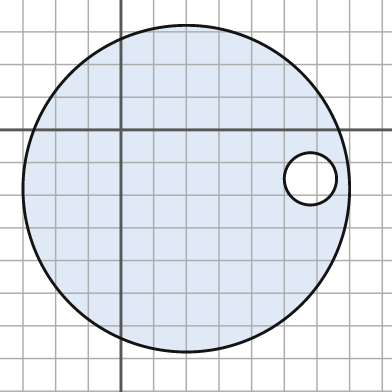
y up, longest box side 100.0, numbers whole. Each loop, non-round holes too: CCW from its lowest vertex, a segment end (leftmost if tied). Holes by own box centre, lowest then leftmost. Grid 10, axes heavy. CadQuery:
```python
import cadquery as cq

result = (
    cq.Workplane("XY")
    .moveTo(20.0, -18.0)
    .circle(50.0)
    .moveTo(58.0, -15.0)
    .circle(8.0)
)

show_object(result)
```